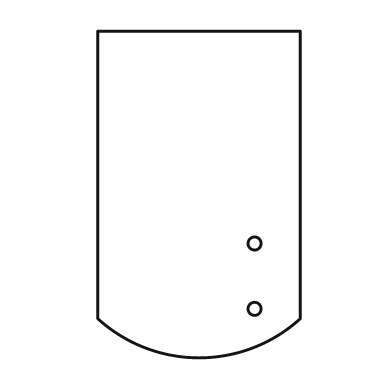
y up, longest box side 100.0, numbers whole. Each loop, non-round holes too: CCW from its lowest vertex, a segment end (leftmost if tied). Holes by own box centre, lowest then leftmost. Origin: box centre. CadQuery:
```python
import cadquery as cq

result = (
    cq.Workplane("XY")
    .moveTo(-31.0, -38.0)
    .threePointArc((0.0, -50.0), (31.0, -38.0))
    .lineTo(31.0, 50.0)
    .lineTo(-31.0, 50.0)
    .close()
    .moveTo(17.0, -35.0)
    .circle(2.0)
    .moveTo(17.0, -15.0)
    .circle(2.0)
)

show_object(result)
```